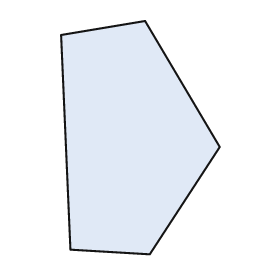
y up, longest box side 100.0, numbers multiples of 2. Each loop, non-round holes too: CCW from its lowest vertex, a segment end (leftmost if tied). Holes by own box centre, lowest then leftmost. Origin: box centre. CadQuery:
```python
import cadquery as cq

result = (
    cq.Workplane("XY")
    .moveTo(4.0, -50.0)
    .lineTo(34.0, -4.0)
    .lineTo(2.0, 50.0)
    .lineTo(-34.0, 44.0)
    .lineTo(-30.0, -48.0)
    .close()
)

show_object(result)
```